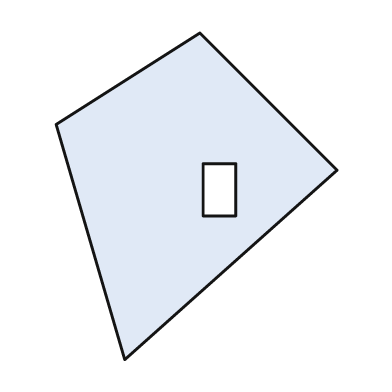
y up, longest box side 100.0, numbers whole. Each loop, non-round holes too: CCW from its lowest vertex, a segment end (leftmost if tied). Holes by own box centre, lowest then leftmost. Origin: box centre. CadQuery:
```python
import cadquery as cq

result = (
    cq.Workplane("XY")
    .moveTo(-22.0, -50.0)
    .lineTo(43.0, 8.0)
    .lineTo(1.0, 50.0)
    .lineTo(-43.0, 22.0)
    .close()
    .moveTo(2.0, -6.0)
    .lineTo(12.0, -6.0)
    .lineTo(12.0, 10.0)
    .lineTo(2.0, 10.0)
    .close()
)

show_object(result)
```